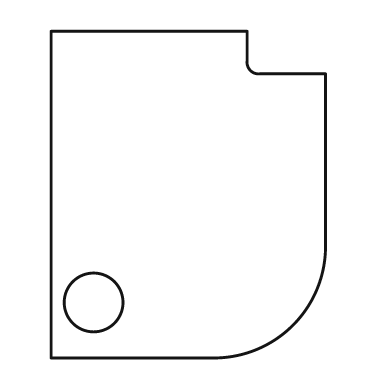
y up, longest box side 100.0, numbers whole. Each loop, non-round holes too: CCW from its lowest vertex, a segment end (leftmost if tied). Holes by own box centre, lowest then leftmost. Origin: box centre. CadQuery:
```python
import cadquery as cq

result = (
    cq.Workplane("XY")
    .moveTo(-42.0, -50.0)
    .lineTo(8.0, -50.0)
    .threePointArc((32.0, -40.0), (42.0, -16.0))
    .lineTo(42.0, 37.0)
    .lineTo(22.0, 37.0)
    .threePointArc((19.0, 38.0), (18.0, 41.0))
    .lineTo(18.0, 50.0)
    .lineTo(-42.0, 50.0)
    .close()
    .moveTo(-29.0, -33.0)
    .circle(9.0)
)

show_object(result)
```